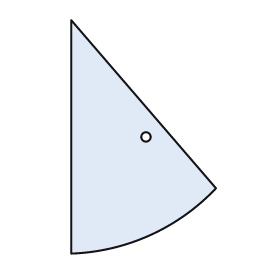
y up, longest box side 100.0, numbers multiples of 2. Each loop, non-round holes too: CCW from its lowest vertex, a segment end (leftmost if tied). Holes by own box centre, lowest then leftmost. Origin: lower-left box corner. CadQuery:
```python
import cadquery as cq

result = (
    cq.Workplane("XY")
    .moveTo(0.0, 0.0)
    .threePointArc((34.0, 8.0), (62.0, 28.0))
    .lineTo(0.0, 100.0)
    .close()
    .moveTo(32.0, 50.0)
    .circle(2.0)
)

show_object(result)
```